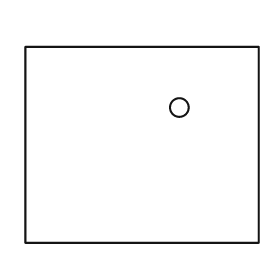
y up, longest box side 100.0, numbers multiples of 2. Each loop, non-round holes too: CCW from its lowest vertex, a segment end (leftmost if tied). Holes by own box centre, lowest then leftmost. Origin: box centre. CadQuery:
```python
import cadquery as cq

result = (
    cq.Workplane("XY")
    .moveTo(-50.0, -42.0)
    .lineTo(50.0, -42.0)
    .lineTo(50.0, 42.0)
    .lineTo(-50.0, 42.0)
    .close()
    .moveTo(16.0, 16.0)
    .circle(4.0)
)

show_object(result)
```